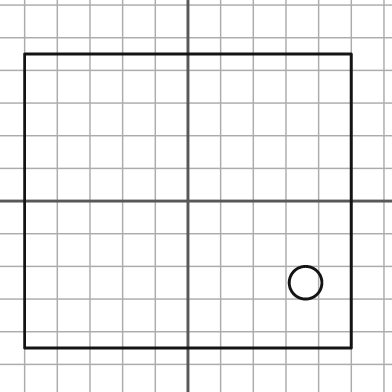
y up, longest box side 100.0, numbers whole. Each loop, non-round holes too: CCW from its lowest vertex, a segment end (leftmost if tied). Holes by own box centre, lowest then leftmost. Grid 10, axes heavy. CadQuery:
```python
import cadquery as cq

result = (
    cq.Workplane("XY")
    .moveTo(-50.0, -45.0)
    .lineTo(50.0, -45.0)
    .lineTo(50.0, 45.0)
    .lineTo(-50.0, 45.0)
    .close()
    .moveTo(36.0, -25.0)
    .circle(5.0)
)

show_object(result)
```